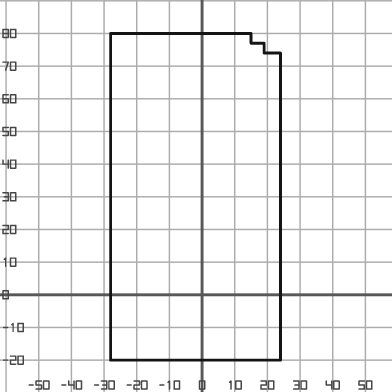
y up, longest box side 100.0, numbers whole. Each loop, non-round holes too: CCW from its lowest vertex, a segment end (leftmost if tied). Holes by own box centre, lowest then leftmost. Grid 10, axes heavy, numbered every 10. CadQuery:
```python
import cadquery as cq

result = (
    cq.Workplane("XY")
    .moveTo(-28.0, -20.0)
    .lineTo(24.0, -20.0)
    .lineTo(24.0, 74.0)
    .lineTo(19.0, 74.0)
    .lineTo(19.0, 77.0)
    .lineTo(15.0, 77.0)
    .lineTo(15.0, 80.0)
    .lineTo(-28.0, 80.0)
    .close()
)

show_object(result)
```